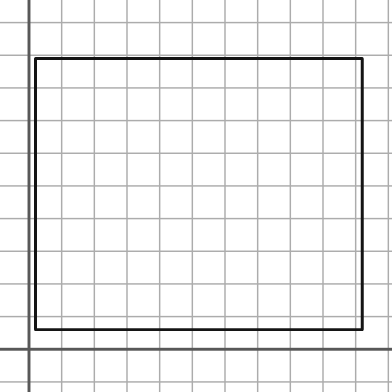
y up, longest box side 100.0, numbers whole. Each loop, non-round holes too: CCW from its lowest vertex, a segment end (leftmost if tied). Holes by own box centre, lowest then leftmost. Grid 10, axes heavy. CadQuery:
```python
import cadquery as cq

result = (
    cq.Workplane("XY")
    .moveTo(2.0, 6.0)
    .lineTo(102.0, 6.0)
    .lineTo(102.0, 89.0)
    .lineTo(2.0, 89.0)
    .close()
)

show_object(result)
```